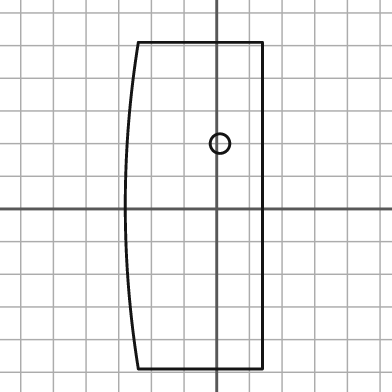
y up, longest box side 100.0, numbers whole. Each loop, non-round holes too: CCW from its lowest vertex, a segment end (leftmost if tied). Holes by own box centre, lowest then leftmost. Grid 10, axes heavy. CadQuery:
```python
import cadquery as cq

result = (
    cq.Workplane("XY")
    .moveTo(-24.0, -49.0)
    .lineTo(14.0, -49.0)
    .lineTo(14.0, 51.0)
    .lineTo(-24.0, 51.0)
    .threePointArc((-28.0, 1.0), (-24.0, -49.0))
    .close()
    .moveTo(1.0, 20.0)
    .circle(3.0)
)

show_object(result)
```